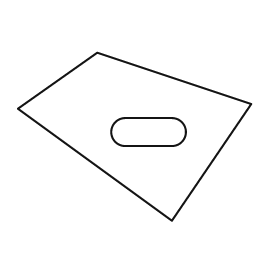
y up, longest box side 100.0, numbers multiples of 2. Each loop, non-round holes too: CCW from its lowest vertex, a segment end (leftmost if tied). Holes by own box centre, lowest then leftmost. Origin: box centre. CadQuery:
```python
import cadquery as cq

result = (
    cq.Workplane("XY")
    .moveTo(16.0, -36.0)
    .lineTo(50.0, 14.0)
    .lineTo(-16.0, 36.0)
    .lineTo(-50.0, 12.0)
    .close()
    .moveTo(-4.0, -4.0)
    .lineTo(16.0, -4.0)
    .threePointArc((22.0, 2.0), (16.0, 8.0))
    .lineTo(-4.0, 8.0)
    .threePointArc((-10.0, 2.0), (-4.0, -4.0))
    .close()
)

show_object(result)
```